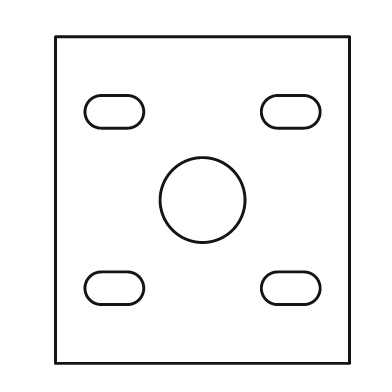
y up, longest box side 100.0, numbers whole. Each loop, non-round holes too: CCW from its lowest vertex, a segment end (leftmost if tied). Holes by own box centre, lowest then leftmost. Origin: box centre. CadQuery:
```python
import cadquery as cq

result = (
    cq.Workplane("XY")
    .moveTo(-45.0, -50.0)
    .lineTo(45.0, -50.0)
    .lineTo(45.0, 50.0)
    .lineTo(-45.0, 50.0)
    .close()
    .moveTo(-31.0, -32.0)
    .lineTo(-23.0, -32.0)
    .threePointArc((-18.0, -27.0), (-23.0, -22.0))
    .lineTo(-31.0, -22.0)
    .threePointArc((-36.0, -27.0), (-31.0, -32.0))
    .close()
    .moveTo(23.0, -32.0)
    .lineTo(31.0, -32.0)
    .threePointArc((36.0, -27.0), (31.0, -22.0))
    .lineTo(23.0, -22.0)
    .threePointArc((18.0, -27.0), (23.0, -32.0))
    .close()
    .moveTo(0.0, 0.0)
    .circle(13.0)
    .moveTo(-31.0, 22.0)
    .lineTo(-23.0, 22.0)
    .threePointArc((-18.0, 27.0), (-23.0, 32.0))
    .lineTo(-31.0, 32.0)
    .threePointArc((-36.0, 27.0), (-31.0, 22.0))
    .close()
    .moveTo(23.0, 22.0)
    .lineTo(31.0, 22.0)
    .threePointArc((36.0, 27.0), (31.0, 32.0))
    .lineTo(23.0, 32.0)
    .threePointArc((18.0, 27.0), (23.0, 22.0))
    .close()
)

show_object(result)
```